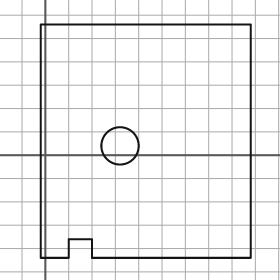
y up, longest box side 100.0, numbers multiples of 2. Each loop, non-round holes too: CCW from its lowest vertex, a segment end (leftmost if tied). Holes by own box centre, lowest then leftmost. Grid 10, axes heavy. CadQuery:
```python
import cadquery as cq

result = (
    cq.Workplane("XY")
    .moveTo(-2.0, -44.0)
    .lineTo(10.0, -44.0)
    .lineTo(10.0, -36.0)
    .lineTo(20.0, -36.0)
    .lineTo(20.0, -44.0)
    .lineTo(88.0, -44.0)
    .lineTo(88.0, 56.0)
    .lineTo(-2.0, 56.0)
    .close()
    .moveTo(32.0, 4.0)
    .circle(8.0)
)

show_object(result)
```